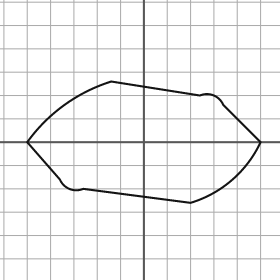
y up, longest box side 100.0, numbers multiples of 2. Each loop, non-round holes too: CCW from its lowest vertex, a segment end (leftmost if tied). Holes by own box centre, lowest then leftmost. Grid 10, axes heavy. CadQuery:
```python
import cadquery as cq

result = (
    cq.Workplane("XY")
    .moveTo(20.0, -26.0)
    .threePointArc((38.0, -16.0), (50.0, 0.0))
    .lineTo(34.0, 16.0)
    .threePointArc((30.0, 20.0), (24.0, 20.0))
    .lineTo(-14.0, 26.0)
    .threePointArc((-34.0, 16.0), (-50.0, 0.0))
    .lineTo(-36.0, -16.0)
    .threePointArc((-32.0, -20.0), (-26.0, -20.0))
    .close()
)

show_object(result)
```